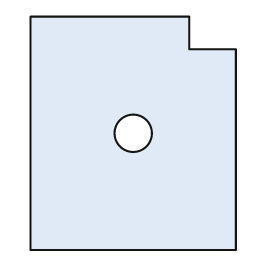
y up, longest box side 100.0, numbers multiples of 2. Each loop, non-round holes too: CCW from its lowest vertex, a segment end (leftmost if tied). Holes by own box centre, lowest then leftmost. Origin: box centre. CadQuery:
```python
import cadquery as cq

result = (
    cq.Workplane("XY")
    .moveTo(-44.0, -50.0)
    .lineTo(44.0, -50.0)
    .lineTo(44.0, 36.0)
    .lineTo(24.0, 36.0)
    .lineTo(24.0, 50.0)
    .lineTo(-44.0, 50.0)
    .close()
    .moveTo(0.0, 0.0)
    .circle(8.0)
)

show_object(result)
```